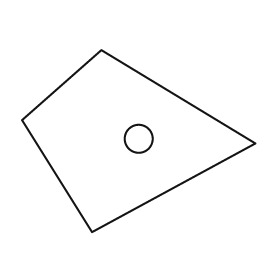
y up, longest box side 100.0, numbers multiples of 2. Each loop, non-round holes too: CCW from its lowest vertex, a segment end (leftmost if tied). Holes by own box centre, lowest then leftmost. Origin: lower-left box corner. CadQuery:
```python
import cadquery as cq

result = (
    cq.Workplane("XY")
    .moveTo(30.0, 0.0)
    .lineTo(100.0, 38.0)
    .lineTo(34.0, 78.0)
    .lineTo(0.0, 48.0)
    .close()
    .moveTo(50.0, 40.0)
    .circle(6.0)
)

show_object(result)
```